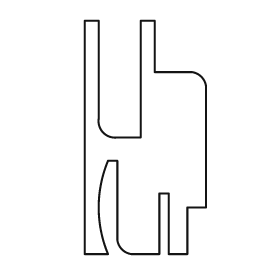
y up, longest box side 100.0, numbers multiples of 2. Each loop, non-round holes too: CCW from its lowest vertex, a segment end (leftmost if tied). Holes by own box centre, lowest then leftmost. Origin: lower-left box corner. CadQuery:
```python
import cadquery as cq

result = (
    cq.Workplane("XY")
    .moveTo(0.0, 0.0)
    .lineTo(10.0, 0.0)
    .threePointArc((6.0, 20.0), (10.0, 40.0))
    .lineTo(14.0, 40.0)
    .lineTo(14.0, 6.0)
    .threePointArc((16.0, 2.0), (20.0, 0.0))
    .lineTo(32.0, 0.0)
    .lineTo(32.0, 26.0)
    .lineTo(36.0, 26.0)
    .lineTo(36.0, 0.0)
    .lineTo(44.0, 0.0)
    .lineTo(44.0, 20.0)
    .lineTo(52.0, 20.0)
    .lineTo(52.0, 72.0)
    .threePointArc((50.0, 76.0), (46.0, 78.0))
    .lineTo(30.0, 78.0)
    .lineTo(30.0, 100.0)
    .lineTo(24.0, 100.0)
    .lineTo(24.0, 50.0)
    .lineTo(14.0, 50.0)
    .threePointArc((8.0, 52.0), (6.0, 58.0))
    .lineTo(6.0, 100.0)
    .lineTo(0.0, 100.0)
    .close()
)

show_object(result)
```